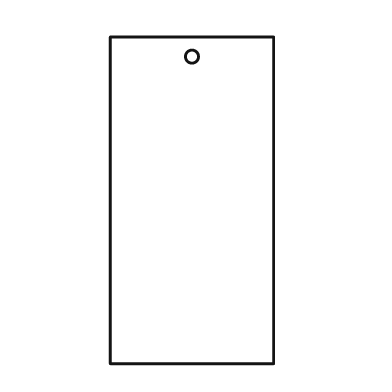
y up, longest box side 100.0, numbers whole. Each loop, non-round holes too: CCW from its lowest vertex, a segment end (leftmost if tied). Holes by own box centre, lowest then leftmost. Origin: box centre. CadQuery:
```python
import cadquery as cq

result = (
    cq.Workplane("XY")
    .moveTo(-25.0, -50.0)
    .lineTo(25.0, -50.0)
    .lineTo(25.0, 50.0)
    .lineTo(-25.0, 50.0)
    .close()
    .moveTo(0.0, 44.0)
    .circle(2.0)
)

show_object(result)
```